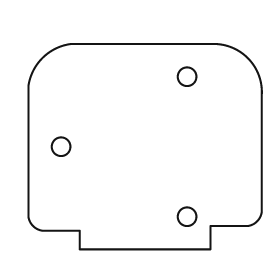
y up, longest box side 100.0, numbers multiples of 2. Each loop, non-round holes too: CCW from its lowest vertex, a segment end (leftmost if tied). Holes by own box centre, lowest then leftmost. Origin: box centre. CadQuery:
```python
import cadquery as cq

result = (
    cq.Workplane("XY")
    .moveTo(-28.0, -44.0)
    .lineTo(28.0, -44.0)
    .lineTo(28.0, -34.0)
    .lineTo(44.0, -34.0)
    .threePointArc((48.0, -32.0), (50.0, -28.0))
    .lineTo(50.0, 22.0)
    .threePointArc((44.0, 38.0), (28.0, 44.0))
    .lineTo(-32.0, 44.0)
    .threePointArc((-44.0, 38.0), (-50.0, 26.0))
    .lineTo(-50.0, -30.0)
    .threePointArc((-48.0, -34.0), (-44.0, -36.0))
    .lineTo(-28.0, -36.0)
    .close()
    .moveTo(18.0, -30.0)
    .circle(4.0)
    .moveTo(-36.0, 0.0)
    .circle(4.0)
    .moveTo(18.0, 30.0)
    .circle(4.0)
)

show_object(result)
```